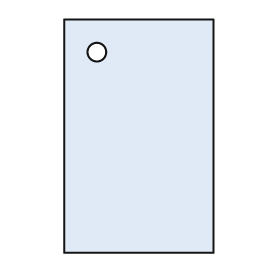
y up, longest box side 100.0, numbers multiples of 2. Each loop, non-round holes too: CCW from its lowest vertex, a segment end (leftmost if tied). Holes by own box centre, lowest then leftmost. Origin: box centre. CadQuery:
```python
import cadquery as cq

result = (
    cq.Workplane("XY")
    .moveTo(-32.0, -50.0)
    .lineTo(32.0, -50.0)
    .lineTo(32.0, 50.0)
    .lineTo(-32.0, 50.0)
    .close()
    .moveTo(-18.0, 36.0)
    .circle(4.0)
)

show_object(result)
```